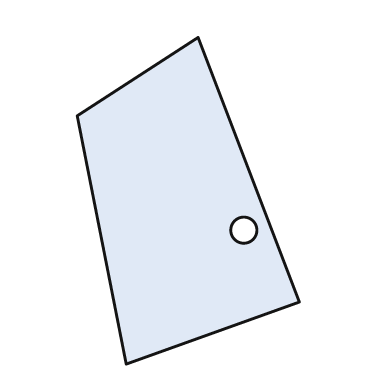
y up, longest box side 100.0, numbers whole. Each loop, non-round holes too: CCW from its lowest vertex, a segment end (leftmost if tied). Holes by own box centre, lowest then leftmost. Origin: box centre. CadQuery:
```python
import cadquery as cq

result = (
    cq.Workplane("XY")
    .moveTo(-19.0, -50.0)
    .lineTo(34.0, -31.0)
    .lineTo(3.0, 50.0)
    .lineTo(-34.0, 26.0)
    .close()
    .moveTo(17.0, -9.0)
    .circle(4.0)
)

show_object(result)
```